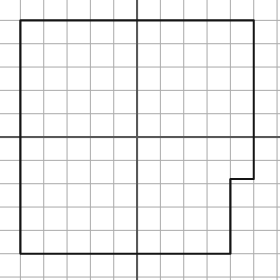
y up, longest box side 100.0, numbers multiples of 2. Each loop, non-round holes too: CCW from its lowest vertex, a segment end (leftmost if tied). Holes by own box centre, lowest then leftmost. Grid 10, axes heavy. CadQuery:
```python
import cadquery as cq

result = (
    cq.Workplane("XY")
    .moveTo(-50.0, -50.0)
    .lineTo(40.0, -50.0)
    .lineTo(40.0, -18.0)
    .lineTo(50.0, -18.0)
    .lineTo(50.0, 50.0)
    .lineTo(-50.0, 50.0)
    .close()
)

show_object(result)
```